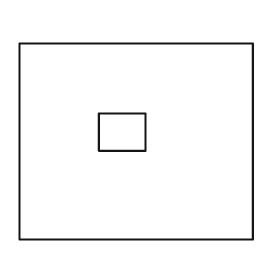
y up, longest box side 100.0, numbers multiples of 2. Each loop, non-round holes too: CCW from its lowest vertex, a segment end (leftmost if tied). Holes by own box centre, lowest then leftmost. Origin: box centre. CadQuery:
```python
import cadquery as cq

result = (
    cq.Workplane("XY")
    .moveTo(-50.0, -42.0)
    .lineTo(50.0, -42.0)
    .lineTo(50.0, 42.0)
    .lineTo(-50.0, 42.0)
    .close()
    .moveTo(-16.0, -4.0)
    .lineTo(4.0, -4.0)
    .lineTo(4.0, 12.0)
    .lineTo(-16.0, 12.0)
    .close()
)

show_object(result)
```